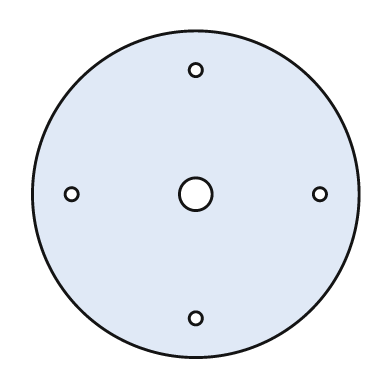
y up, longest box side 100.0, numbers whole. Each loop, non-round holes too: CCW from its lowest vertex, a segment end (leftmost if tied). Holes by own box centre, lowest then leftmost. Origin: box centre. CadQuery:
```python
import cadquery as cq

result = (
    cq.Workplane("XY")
    .moveTo(0.0, 0.0)
    .circle(50.0)
    .moveTo(0.0, -38.0)
    .circle(2.0)
    .moveTo(-38.0, 0.0)
    .circle(2.0)
    .moveTo(0.0, 0.0)
    .circle(5.0)
    .moveTo(38.0, 0.0)
    .circle(2.0)
    .moveTo(0.0, 38.0)
    .circle(2.0)
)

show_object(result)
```